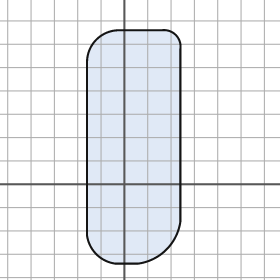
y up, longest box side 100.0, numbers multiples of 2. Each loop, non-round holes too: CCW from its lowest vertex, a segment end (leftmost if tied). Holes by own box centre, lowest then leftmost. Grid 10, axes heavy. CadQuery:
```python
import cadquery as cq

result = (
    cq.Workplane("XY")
    .moveTo(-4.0, -34.0)
    .lineTo(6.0, -34.0)
    .threePointArc((18.0, -28.0), (24.0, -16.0))
    .lineTo(24.0, 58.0)
    .threePointArc((22.0, 64.0), (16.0, 66.0))
    .lineTo(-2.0, 66.0)
    .threePointArc((-12.0, 62.0), (-16.0, 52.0))
    .lineTo(-16.0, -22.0)
    .threePointArc((-12.0, -30.0), (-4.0, -34.0))
    .close()
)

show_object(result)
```